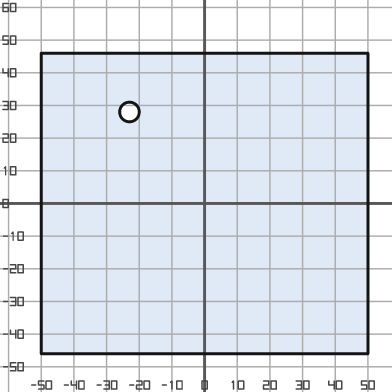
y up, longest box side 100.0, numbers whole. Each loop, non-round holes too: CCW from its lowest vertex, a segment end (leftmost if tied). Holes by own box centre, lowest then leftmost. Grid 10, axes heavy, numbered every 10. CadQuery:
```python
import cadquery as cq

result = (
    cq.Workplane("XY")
    .moveTo(-50.0, -46.0)
    .lineTo(50.0, -46.0)
    .lineTo(50.0, 46.0)
    .lineTo(-50.0, 46.0)
    .close()
    .moveTo(-23.0, 28.0)
    .circle(3.0)
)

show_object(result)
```